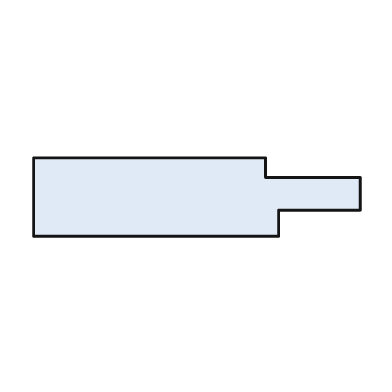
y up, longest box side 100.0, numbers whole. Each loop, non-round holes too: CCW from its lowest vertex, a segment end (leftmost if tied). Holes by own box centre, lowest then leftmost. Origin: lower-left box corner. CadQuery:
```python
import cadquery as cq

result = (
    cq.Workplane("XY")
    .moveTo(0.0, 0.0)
    .lineTo(75.0, 0.0)
    .lineTo(75.0, 8.0)
    .lineTo(100.0, 8.0)
    .lineTo(100.0, 18.0)
    .lineTo(71.0, 18.0)
    .lineTo(71.0, 24.0)
    .lineTo(0.0, 24.0)
    .close()
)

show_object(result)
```